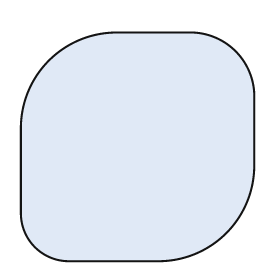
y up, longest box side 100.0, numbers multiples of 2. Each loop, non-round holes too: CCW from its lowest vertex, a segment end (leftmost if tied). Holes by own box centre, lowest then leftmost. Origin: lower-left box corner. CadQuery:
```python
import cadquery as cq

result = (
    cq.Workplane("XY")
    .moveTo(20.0, 0.0)
    .lineTo(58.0, 0.0)
    .threePointArc((88.0, 12.0), (100.0, 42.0))
    .lineTo(100.0, 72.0)
    .threePointArc((92.0, 90.0), (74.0, 98.0))
    .lineTo(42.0, 98.0)
    .threePointArc((12.0, 86.0), (0.0, 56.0))
    .lineTo(0.0, 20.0)
    .threePointArc((6.0, 6.0), (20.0, 0.0))
    .close()
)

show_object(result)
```